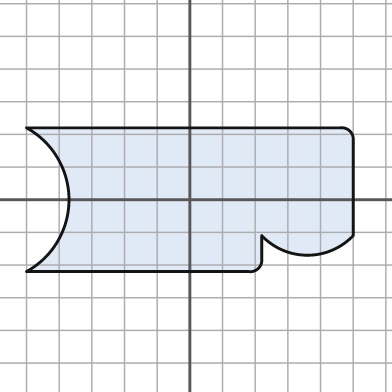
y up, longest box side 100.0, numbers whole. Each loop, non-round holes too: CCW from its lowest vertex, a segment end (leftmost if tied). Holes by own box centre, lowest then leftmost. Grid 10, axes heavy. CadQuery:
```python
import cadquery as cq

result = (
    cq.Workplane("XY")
    .moveTo(-50.0, -22.0)
    .lineTo(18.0, -22.0)
    .threePointArc((21.0, -21.0), (22.0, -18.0))
    .lineTo(22.0, -11.0)
    .threePointArc((36.0, -17.0), (50.0, -11.0))
    .lineTo(50.0, 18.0)
    .threePointArc((49.0, 21.0), (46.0, 22.0))
    .lineTo(-50.0, 22.0)
    .threePointArc((-37.0, 0.0), (-50.0, -22.0))
    .close()
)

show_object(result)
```